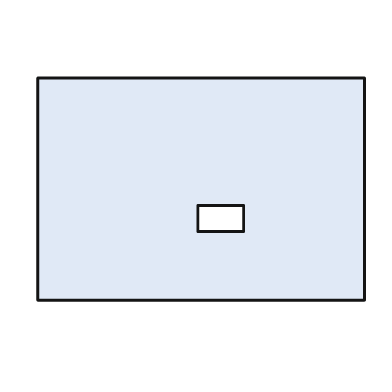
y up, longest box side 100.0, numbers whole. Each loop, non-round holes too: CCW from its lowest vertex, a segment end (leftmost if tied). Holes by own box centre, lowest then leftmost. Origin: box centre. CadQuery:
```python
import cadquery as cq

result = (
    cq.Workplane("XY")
    .moveTo(-50.0, -34.0)
    .lineTo(50.0, -34.0)
    .lineTo(50.0, 34.0)
    .lineTo(-50.0, 34.0)
    .close()
    .moveTo(-1.0, -13.0)
    .lineTo(13.0, -13.0)
    .lineTo(13.0, -5.0)
    .lineTo(-1.0, -5.0)
    .close()
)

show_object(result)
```